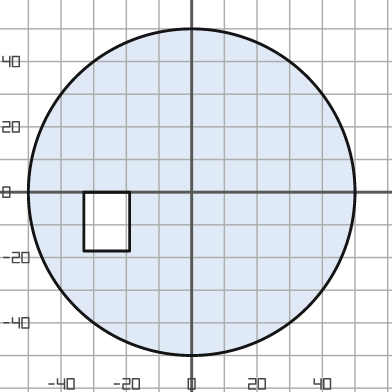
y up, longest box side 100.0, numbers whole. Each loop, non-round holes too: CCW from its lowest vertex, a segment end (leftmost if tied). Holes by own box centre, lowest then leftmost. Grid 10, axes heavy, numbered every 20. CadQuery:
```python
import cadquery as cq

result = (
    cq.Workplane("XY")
    .moveTo(0.0, 0.0)
    .circle(50.0)
    .moveTo(-33.0, -18.0)
    .lineTo(-19.0, -18.0)
    .lineTo(-19.0, 0.0)
    .lineTo(-33.0, 0.0)
    .close()
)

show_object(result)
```